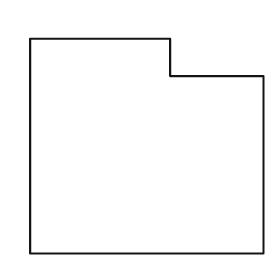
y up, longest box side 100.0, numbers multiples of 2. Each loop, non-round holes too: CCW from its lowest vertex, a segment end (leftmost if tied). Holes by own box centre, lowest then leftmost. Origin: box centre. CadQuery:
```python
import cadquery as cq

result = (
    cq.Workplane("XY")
    .moveTo(-50.0, -46.0)
    .lineTo(50.0, -46.0)
    .lineTo(50.0, 30.0)
    .lineTo(10.0, 30.0)
    .lineTo(10.0, 46.0)
    .lineTo(-50.0, 46.0)
    .close()
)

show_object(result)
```